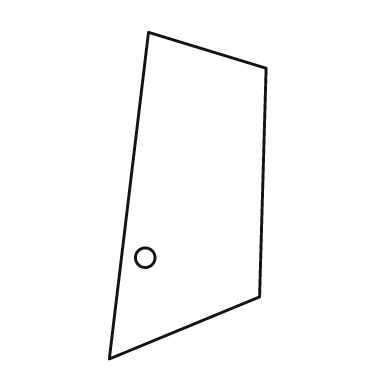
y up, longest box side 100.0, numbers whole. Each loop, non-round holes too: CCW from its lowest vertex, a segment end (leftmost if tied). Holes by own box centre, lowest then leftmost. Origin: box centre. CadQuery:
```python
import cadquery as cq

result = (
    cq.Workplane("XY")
    .moveTo(-24.0, -50.0)
    .lineTo(22.0, -31.0)
    .lineTo(24.0, 39.0)
    .lineTo(-12.0, 50.0)
    .close()
    .moveTo(-13.0, -19.0)
    .circle(3.0)
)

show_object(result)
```